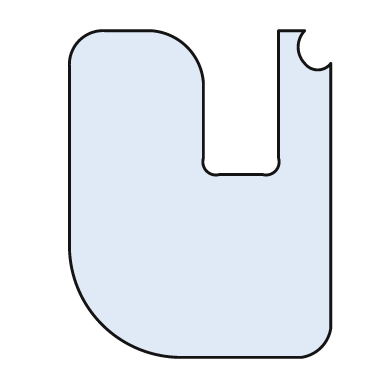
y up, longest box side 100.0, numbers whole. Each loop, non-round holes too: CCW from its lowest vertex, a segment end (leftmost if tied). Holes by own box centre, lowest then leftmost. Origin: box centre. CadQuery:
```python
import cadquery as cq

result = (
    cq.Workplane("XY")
    .moveTo(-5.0, -50.0)
    .lineTo(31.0, -50.0)
    .threePointArc((37.0, -47.0), (40.0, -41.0))
    .lineTo(40.0, 40.0)
    .threePointArc((36.0, 38.0), (32.0, 40.0))
    .threePointArc((30.0, 45.0), (32.0, 50.0))
    .lineTo(24.0, 50.0)
    .lineTo(24.0, 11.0)
    .threePointArc((23.0, 7.0), (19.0, 6.0))
    .lineTo(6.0, 6.0)
    .threePointArc((2.0, 7.0), (1.0, 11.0))
    .lineTo(1.0, 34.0)
    .threePointArc((-4.0, 45.0), (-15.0, 50.0))
    .lineTo(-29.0, 50.0)
    .threePointArc((-37.0, 47.0), (-40.0, 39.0))
    .lineTo(-40.0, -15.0)
    .threePointArc((-30.0, -40.0), (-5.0, -50.0))
    .close()
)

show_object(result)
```